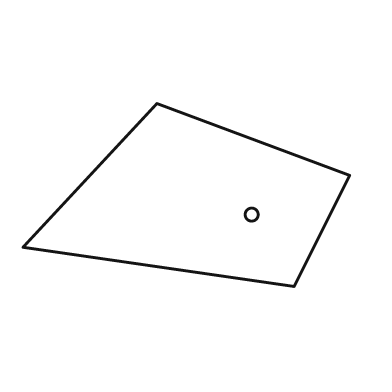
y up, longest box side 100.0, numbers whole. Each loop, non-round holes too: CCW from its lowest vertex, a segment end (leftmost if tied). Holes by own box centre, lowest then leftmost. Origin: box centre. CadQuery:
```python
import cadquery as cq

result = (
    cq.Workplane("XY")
    .moveTo(33.0, -28.0)
    .lineTo(50.0, 6.0)
    .lineTo(-9.0, 28.0)
    .lineTo(-50.0, -16.0)
    .close()
    .moveTo(20.0, -6.0)
    .circle(2.0)
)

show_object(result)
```